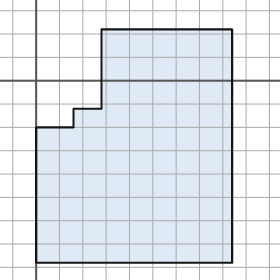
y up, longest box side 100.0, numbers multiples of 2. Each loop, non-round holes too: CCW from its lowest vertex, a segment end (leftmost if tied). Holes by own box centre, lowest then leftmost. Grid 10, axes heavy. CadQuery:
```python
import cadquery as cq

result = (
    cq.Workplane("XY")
    .moveTo(0.0, -78.0)
    .lineTo(84.0, -78.0)
    .lineTo(84.0, 22.0)
    .lineTo(28.0, 22.0)
    .lineTo(28.0, -12.0)
    .lineTo(16.0, -12.0)
    .lineTo(16.0, -20.0)
    .lineTo(0.0, -20.0)
    .close()
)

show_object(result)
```